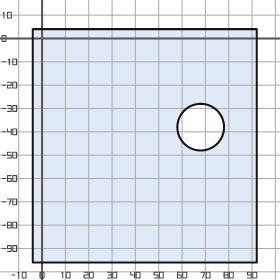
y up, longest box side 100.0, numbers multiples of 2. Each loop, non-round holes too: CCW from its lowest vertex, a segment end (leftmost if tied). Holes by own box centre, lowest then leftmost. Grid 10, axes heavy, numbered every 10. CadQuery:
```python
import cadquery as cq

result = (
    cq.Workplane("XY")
    .moveTo(-4.0, -96.0)
    .lineTo(92.0, -96.0)
    .lineTo(92.0, 4.0)
    .lineTo(-4.0, 4.0)
    .close()
    .moveTo(68.0, -38.0)
    .circle(10.0)
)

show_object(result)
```